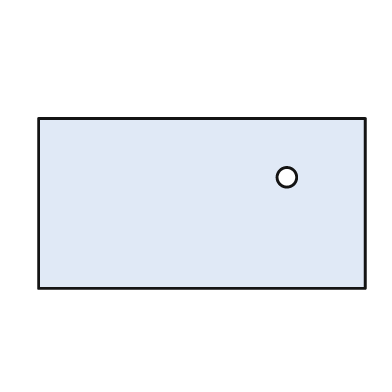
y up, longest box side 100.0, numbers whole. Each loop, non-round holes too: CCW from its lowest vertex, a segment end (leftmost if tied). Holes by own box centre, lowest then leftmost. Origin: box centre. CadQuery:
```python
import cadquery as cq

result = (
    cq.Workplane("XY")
    .moveTo(-50.0, -26.0)
    .lineTo(50.0, -26.0)
    .lineTo(50.0, 26.0)
    .lineTo(-50.0, 26.0)
    .close()
    .moveTo(26.0, 8.0)
    .circle(3.0)
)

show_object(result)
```